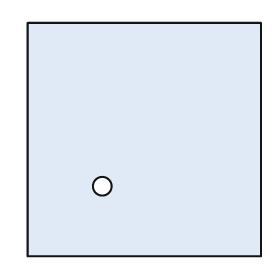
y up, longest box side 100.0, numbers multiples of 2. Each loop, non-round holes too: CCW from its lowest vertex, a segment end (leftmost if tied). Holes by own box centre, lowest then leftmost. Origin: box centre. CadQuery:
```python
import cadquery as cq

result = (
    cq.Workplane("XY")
    .moveTo(-50.0, -50.0)
    .lineTo(50.0, -50.0)
    .lineTo(50.0, 50.0)
    .lineTo(-50.0, 50.0)
    .close()
    .moveTo(-18.0, -20.0)
    .circle(4.0)
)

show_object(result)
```